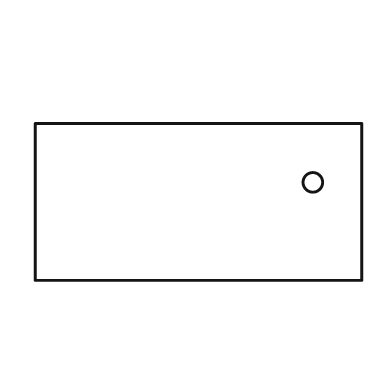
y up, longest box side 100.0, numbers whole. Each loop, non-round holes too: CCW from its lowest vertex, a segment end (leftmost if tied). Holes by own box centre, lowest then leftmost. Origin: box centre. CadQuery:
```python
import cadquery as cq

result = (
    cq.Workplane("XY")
    .moveTo(-50.0, -24.0)
    .lineTo(50.0, -24.0)
    .lineTo(50.0, 24.0)
    .lineTo(-50.0, 24.0)
    .close()
    .moveTo(35.0, 6.0)
    .circle(3.0)
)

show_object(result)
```